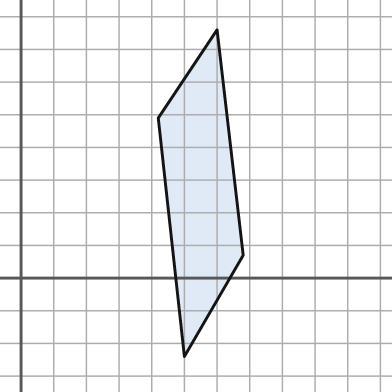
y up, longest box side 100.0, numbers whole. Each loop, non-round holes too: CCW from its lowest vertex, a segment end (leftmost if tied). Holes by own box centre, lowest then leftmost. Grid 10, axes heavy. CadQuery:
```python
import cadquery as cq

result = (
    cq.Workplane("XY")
    .moveTo(50.0, -24.0)
    .lineTo(68.0, 7.0)
    .lineTo(60.0, 76.0)
    .lineTo(42.0, 49.0)
    .close()
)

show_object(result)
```